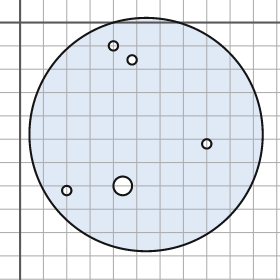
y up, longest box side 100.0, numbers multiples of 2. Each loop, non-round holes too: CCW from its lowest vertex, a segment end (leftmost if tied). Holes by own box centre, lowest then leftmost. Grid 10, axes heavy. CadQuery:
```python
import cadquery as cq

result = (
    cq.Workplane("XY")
    .moveTo(54.0, -48.0)
    .circle(50.0)
    .moveTo(20.0, -72.0)
    .circle(2.0)
    .moveTo(44.0, -70.0)
    .circle(4.0)
    .moveTo(80.0, -52.0)
    .circle(2.0)
    .moveTo(48.0, -16.0)
    .circle(2.0)
    .moveTo(40.0, -10.0)
    .circle(2.0)
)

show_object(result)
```